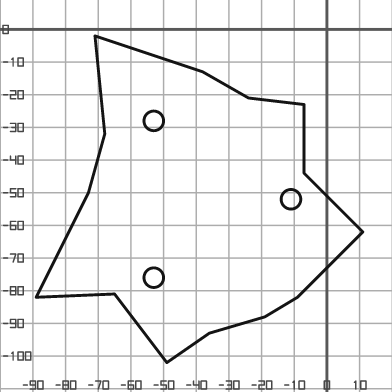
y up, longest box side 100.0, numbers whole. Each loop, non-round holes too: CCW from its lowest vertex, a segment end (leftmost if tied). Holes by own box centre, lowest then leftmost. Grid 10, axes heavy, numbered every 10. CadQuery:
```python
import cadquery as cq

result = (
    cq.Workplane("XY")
    .moveTo(-49.0, -102.0)
    .lineTo(-36.0, -93.0)
    .lineTo(-19.0, -88.0)
    .lineTo(-9.0, -82.0)
    .lineTo(11.0, -62.0)
    .lineTo(-7.0, -44.0)
    .lineTo(-7.0, -23.0)
    .lineTo(-24.0, -21.0)
    .lineTo(-38.0, -13.0)
    .lineTo(-71.0, -2.0)
    .lineTo(-68.0, -32.0)
    .lineTo(-73.0, -50.0)
    .lineTo(-89.0, -82.0)
    .lineTo(-65.0, -81.0)
    .close()
    .moveTo(-53.0, -76.0)
    .circle(3.0)
    .moveTo(-11.0, -52.0)
    .circle(3.0)
    .moveTo(-53.0, -28.0)
    .circle(3.0)
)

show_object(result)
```